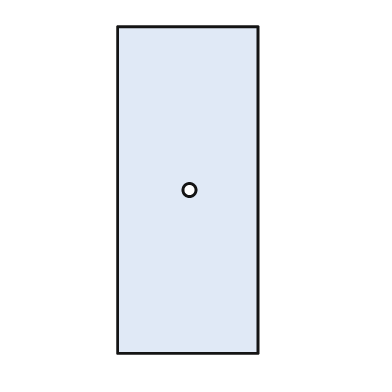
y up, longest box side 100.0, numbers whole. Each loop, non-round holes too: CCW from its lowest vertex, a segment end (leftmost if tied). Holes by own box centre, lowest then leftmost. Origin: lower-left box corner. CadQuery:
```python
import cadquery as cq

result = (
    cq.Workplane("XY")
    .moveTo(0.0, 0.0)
    .lineTo(43.0, 0.0)
    .lineTo(43.0, 100.0)
    .lineTo(0.0, 100.0)
    .close()
    .moveTo(22.0, 50.0)
    .circle(2.0)
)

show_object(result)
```